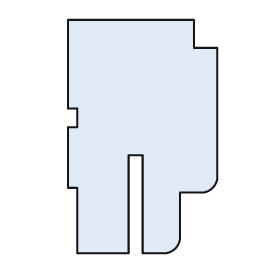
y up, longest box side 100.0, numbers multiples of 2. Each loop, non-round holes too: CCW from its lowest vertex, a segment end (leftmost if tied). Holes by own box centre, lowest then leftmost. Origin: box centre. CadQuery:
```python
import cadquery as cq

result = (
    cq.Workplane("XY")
    .moveTo(-28.0, -50.0)
    .lineTo(-6.0, -50.0)
    .lineTo(-6.0, -8.0)
    .lineTo(0.0, -8.0)
    .lineTo(0.0, -50.0)
    .lineTo(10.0, -50.0)
    .threePointArc((14.0, -48.0), (16.0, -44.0))
    .lineTo(16.0, -24.0)
    .lineTo(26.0, -24.0)
    .threePointArc((30.0, -22.0), (32.0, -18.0))
    .lineTo(32.0, 38.0)
    .lineTo(22.0, 38.0)
    .lineTo(22.0, 50.0)
    .lineTo(-32.0, 50.0)
    .lineTo(-32.0, 12.0)
    .lineTo(-28.0, 12.0)
    .lineTo(-28.0, 4.0)
    .lineTo(-32.0, 4.0)
    .lineTo(-32.0, -22.0)
    .lineTo(-28.0, -22.0)
    .close()
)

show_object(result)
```